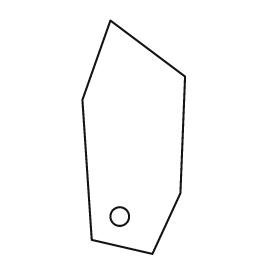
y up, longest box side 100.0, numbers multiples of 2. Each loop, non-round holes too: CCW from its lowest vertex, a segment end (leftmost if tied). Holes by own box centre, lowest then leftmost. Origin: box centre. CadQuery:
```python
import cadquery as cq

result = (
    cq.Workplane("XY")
    .moveTo(8.0, -50.0)
    .lineTo(20.0, -24.0)
    .lineTo(22.0, 26.0)
    .lineTo(-10.0, 50.0)
    .lineTo(-22.0, 16.0)
    .lineTo(-18.0, -44.0)
    .close()
    .moveTo(-6.0, -34.0)
    .circle(4.0)
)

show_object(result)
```